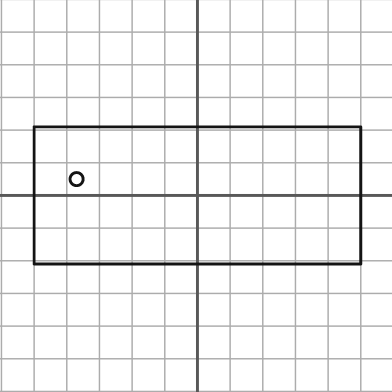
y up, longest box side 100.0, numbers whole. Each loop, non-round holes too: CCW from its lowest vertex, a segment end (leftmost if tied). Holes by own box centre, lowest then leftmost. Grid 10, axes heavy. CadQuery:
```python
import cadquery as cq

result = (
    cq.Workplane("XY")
    .moveTo(-50.0, -21.0)
    .lineTo(50.0, -21.0)
    .lineTo(50.0, 21.0)
    .lineTo(-50.0, 21.0)
    .close()
    .moveTo(-37.0, 5.0)
    .circle(2.0)
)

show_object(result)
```